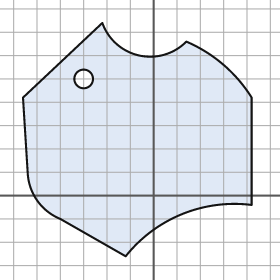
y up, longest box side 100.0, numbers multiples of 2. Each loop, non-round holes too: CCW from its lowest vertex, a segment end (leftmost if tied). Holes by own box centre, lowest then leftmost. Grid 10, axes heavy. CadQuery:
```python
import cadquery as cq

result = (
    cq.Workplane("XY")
    .moveTo(-12.0, -26.0)
    .threePointArc((12.0, -8.0), (42.0, -4.0))
    .lineTo(42.0, 42.0)
    .threePointArc((30.0, 56.0), (14.0, 66.0))
    .threePointArc((-6.0, 60.0), (-22.0, 74.0))
    .lineTo(-56.0, 42.0)
    .lineTo(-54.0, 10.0)
    .threePointArc((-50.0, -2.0), (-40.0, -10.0))
    .close()
    .moveTo(-30.0, 50.0)
    .circle(4.0)
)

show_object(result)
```